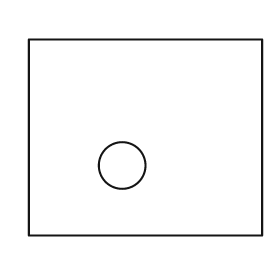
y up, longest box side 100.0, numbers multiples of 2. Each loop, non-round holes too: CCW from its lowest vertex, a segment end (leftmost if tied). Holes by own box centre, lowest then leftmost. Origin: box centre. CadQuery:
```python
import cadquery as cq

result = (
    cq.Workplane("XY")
    .moveTo(-50.0, -42.0)
    .lineTo(50.0, -42.0)
    .lineTo(50.0, 42.0)
    .lineTo(-50.0, 42.0)
    .close()
    .moveTo(-10.0, -12.0)
    .circle(10.0)
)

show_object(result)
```